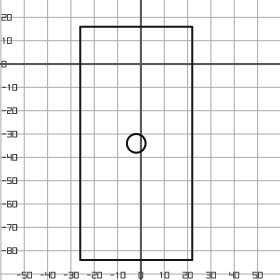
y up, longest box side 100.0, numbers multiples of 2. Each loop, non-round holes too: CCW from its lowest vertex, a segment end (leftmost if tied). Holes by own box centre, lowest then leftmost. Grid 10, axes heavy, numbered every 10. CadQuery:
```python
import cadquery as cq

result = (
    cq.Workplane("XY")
    .moveTo(-26.0, -84.0)
    .lineTo(22.0, -84.0)
    .lineTo(22.0, 16.0)
    .lineTo(-26.0, 16.0)
    .close()
    .moveTo(-2.0, -34.0)
    .circle(4.0)
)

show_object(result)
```